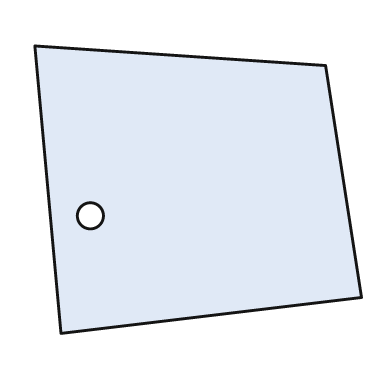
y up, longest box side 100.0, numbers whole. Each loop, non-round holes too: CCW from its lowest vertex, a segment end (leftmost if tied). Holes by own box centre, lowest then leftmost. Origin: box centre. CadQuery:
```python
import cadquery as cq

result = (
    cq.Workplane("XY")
    .moveTo(-42.0, -44.0)
    .lineTo(50.0, -33.0)
    .lineTo(39.0, 38.0)
    .lineTo(-50.0, 44.0)
    .close()
    .moveTo(-33.0, -8.0)
    .circle(4.0)
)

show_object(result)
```